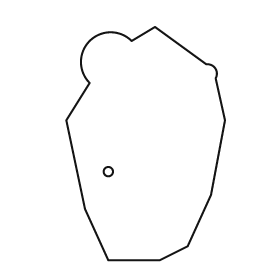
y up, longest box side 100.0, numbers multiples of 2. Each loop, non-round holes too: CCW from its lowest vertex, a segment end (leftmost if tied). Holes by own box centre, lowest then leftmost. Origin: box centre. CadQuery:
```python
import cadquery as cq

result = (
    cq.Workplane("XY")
    .moveTo(-16.0, -50.0)
    .lineTo(6.0, -50.0)
    .lineTo(18.0, -44.0)
    .lineTo(28.0, -22.0)
    .lineTo(34.0, 10.0)
    .lineTo(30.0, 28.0)
    .threePointArc((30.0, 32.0), (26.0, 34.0))
    .lineTo(4.0, 50.0)
    .lineTo(-6.0, 44.0)
    .threePointArc((-24.0, 44.0), (-24.0, 26.0))
    .lineTo(-34.0, 10.0)
    .lineTo(-26.0, -28.0)
    .close()
    .moveTo(-16.0, -12.0)
    .circle(2.0)
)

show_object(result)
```